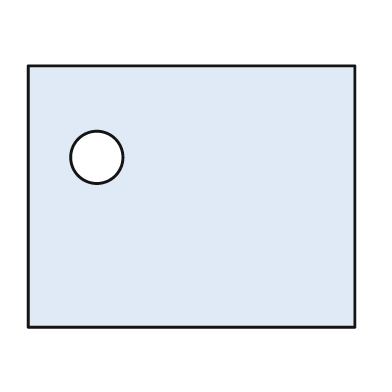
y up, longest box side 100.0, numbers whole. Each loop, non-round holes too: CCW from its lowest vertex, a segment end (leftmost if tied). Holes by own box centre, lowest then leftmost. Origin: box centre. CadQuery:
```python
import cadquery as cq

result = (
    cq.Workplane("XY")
    .moveTo(-50.0, -40.0)
    .lineTo(50.0, -40.0)
    .lineTo(50.0, 40.0)
    .lineTo(-50.0, 40.0)
    .close()
    .moveTo(-29.0, 12.0)
    .circle(8.0)
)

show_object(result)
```